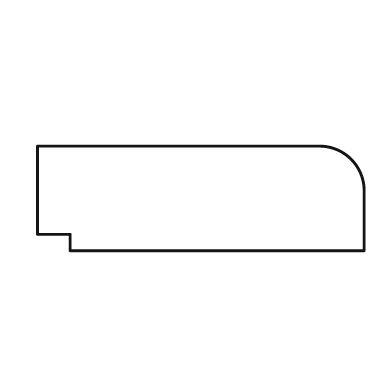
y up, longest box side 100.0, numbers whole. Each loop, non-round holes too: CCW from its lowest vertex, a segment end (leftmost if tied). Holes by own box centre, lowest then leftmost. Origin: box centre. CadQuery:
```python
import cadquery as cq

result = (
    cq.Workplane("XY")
    .moveTo(-40.0, -16.0)
    .lineTo(50.0, -16.0)
    .lineTo(50.0, 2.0)
    .threePointArc((46.0, 12.0), (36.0, 16.0))
    .lineTo(-50.0, 16.0)
    .lineTo(-50.0, -11.0)
    .lineTo(-40.0, -11.0)
    .close()
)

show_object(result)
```